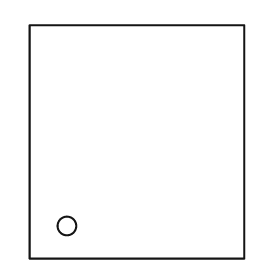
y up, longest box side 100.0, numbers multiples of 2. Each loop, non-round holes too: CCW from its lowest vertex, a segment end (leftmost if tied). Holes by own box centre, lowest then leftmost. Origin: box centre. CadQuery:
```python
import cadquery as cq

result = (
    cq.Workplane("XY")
    .moveTo(-46.0, -50.0)
    .lineTo(46.0, -50.0)
    .lineTo(46.0, 50.0)
    .lineTo(-46.0, 50.0)
    .close()
    .moveTo(-30.0, -36.0)
    .circle(4.0)
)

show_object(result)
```